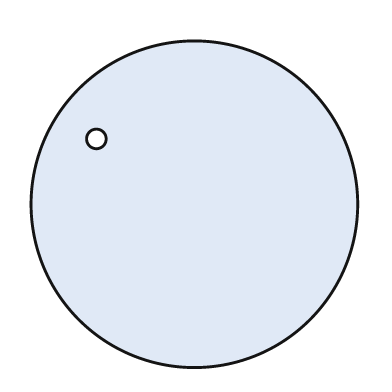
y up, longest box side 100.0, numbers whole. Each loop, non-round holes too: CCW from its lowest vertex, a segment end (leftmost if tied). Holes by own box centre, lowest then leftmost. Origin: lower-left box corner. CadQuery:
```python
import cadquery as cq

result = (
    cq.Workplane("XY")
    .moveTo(50.0, 50.0)
    .circle(50.0)
    .moveTo(20.0, 70.0)
    .circle(3.0)
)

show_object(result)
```